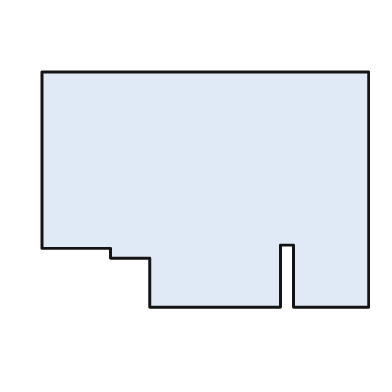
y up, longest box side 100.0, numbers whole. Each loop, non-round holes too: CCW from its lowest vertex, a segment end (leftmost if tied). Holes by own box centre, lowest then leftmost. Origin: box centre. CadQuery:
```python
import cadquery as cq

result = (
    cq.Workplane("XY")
    .moveTo(-17.0, -36.0)
    .lineTo(23.0, -36.0)
    .lineTo(23.0, -17.0)
    .lineTo(27.0, -17.0)
    .lineTo(27.0, -36.0)
    .lineTo(50.0, -36.0)
    .lineTo(50.0, 36.0)
    .lineTo(-50.0, 36.0)
    .lineTo(-50.0, -18.0)
    .lineTo(-29.0, -18.0)
    .lineTo(-29.0, -21.0)
    .lineTo(-17.0, -21.0)
    .close()
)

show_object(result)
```